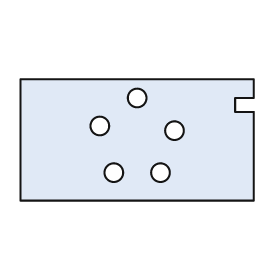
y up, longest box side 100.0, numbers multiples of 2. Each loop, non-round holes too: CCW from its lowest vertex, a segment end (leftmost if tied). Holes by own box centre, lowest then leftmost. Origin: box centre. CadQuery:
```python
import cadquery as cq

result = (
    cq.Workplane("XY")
    .moveTo(-50.0, -26.0)
    .lineTo(50.0, -26.0)
    .lineTo(50.0, 12.0)
    .lineTo(42.0, 12.0)
    .lineTo(42.0, 18.0)
    .lineTo(50.0, 18.0)
    .lineTo(50.0, 26.0)
    .lineTo(-50.0, 26.0)
    .close()
    .moveTo(-10.0, -14.0)
    .circle(4.0)
    .moveTo(10.0, -14.0)
    .circle(4.0)
    .moveTo(16.0, 4.0)
    .circle(4.0)
    .moveTo(-16.0, 6.0)
    .circle(4.0)
    .moveTo(0.0, 18.0)
    .circle(4.0)
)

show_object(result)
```